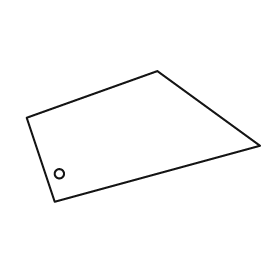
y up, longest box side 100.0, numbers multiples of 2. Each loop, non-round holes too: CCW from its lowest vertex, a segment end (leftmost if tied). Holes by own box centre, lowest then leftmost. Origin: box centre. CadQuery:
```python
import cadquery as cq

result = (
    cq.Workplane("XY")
    .moveTo(-38.0, -28.0)
    .lineTo(50.0, -4.0)
    .lineTo(6.0, 28.0)
    .lineTo(-50.0, 8.0)
    .close()
    .moveTo(-36.0, -16.0)
    .circle(2.0)
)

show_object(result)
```